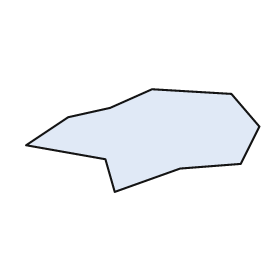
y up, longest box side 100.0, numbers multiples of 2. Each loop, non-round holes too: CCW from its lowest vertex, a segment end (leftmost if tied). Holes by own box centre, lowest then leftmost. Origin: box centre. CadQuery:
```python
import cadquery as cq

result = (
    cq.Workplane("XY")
    .moveTo(-12.0, -22.0)
    .lineTo(16.0, -12.0)
    .lineTo(42.0, -10.0)
    .lineTo(50.0, 6.0)
    .lineTo(38.0, 20.0)
    .lineTo(4.0, 22.0)
    .lineTo(-14.0, 14.0)
    .lineTo(-32.0, 10.0)
    .lineTo(-50.0, -2.0)
    .lineTo(-16.0, -8.0)
    .close()
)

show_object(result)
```